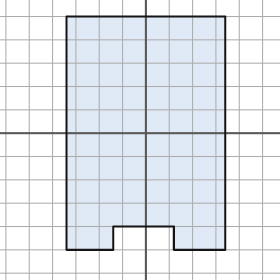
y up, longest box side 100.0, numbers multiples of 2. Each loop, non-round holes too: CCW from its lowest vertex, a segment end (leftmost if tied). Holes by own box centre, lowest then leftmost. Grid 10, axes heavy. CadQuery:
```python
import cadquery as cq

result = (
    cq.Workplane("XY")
    .moveTo(-34.0, -50.0)
    .lineTo(-14.0, -50.0)
    .lineTo(-14.0, -40.0)
    .lineTo(12.0, -40.0)
    .lineTo(12.0, -50.0)
    .lineTo(34.0, -50.0)
    .lineTo(34.0, 50.0)
    .lineTo(-34.0, 50.0)
    .close()
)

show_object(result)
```